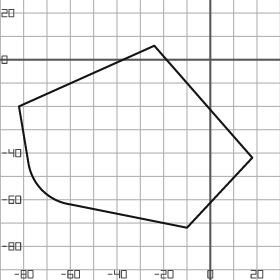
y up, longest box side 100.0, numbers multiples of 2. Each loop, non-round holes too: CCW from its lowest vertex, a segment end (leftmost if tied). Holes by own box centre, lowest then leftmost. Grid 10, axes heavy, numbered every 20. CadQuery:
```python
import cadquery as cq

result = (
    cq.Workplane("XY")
    .moveTo(-10.0, -72.0)
    .lineTo(18.0, -42.0)
    .lineTo(-24.0, 6.0)
    .lineTo(-82.0, -20.0)
    .lineTo(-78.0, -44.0)
    .threePointArc((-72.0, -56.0), (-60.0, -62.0))
    .close()
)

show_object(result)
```